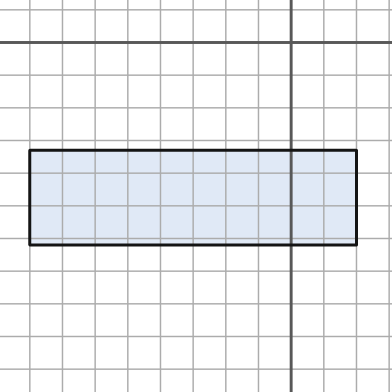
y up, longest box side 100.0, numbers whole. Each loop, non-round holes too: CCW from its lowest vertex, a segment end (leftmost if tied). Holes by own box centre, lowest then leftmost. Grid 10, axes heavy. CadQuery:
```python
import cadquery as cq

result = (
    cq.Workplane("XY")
    .moveTo(-80.0, -62.0)
    .lineTo(20.0, -62.0)
    .lineTo(20.0, -33.0)
    .lineTo(-80.0, -33.0)
    .close()
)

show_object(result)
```